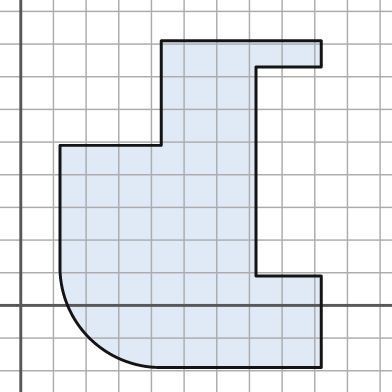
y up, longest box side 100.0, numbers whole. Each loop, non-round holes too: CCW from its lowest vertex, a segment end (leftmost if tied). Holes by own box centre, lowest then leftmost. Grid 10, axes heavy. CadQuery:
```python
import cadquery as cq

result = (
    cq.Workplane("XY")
    .moveTo(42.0, -19.0)
    .lineTo(92.0, -19.0)
    .lineTo(92.0, 9.0)
    .lineTo(72.0, 9.0)
    .lineTo(72.0, 73.0)
    .lineTo(92.0, 73.0)
    .lineTo(92.0, 81.0)
    .lineTo(43.0, 81.0)
    .lineTo(43.0, 49.0)
    .lineTo(12.0, 49.0)
    .lineTo(12.0, 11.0)
    .threePointArc((21.0, -10.0), (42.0, -19.0))
    .close()
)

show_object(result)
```